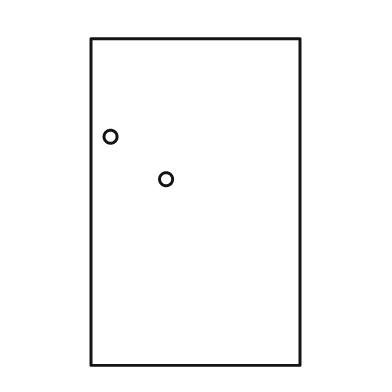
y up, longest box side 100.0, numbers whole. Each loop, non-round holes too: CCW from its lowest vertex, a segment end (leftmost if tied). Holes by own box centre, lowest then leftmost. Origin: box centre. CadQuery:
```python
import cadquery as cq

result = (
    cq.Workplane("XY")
    .moveTo(-32.0, -50.0)
    .lineTo(32.0, -50.0)
    .lineTo(32.0, 50.0)
    .lineTo(-32.0, 50.0)
    .close()
    .moveTo(-9.0, 7.0)
    .circle(2.0)
    .moveTo(-26.0, 20.0)
    .circle(2.0)
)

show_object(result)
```